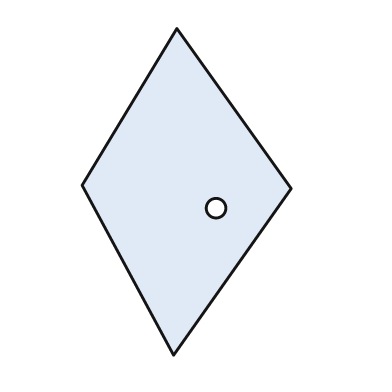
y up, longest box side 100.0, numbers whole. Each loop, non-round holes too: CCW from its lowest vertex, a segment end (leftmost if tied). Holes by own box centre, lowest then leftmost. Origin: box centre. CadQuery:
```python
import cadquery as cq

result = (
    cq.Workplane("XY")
    .moveTo(-4.0, -50.0)
    .lineTo(32.0, 1.0)
    .lineTo(-3.0, 50.0)
    .lineTo(-32.0, 2.0)
    .close()
    .moveTo(9.0, -5.0)
    .circle(3.0)
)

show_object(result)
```